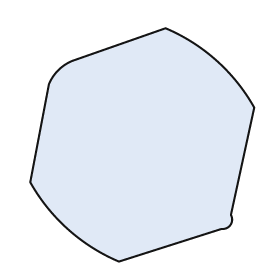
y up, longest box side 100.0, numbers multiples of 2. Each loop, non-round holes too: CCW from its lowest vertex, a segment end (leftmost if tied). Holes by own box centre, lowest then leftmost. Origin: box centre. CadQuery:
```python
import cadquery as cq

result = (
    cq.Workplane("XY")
    .moveTo(-10.0, -50.0)
    .lineTo(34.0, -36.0)
    .threePointArc((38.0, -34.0), (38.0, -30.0))
    .lineTo(48.0, 16.0)
    .threePointArc((32.0, 36.0), (10.0, 50.0))
    .lineTo(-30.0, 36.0)
    .threePointArc((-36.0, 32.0), (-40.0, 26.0))
    .lineTo(-48.0, -16.0)
    .threePointArc((-32.0, -36.0), (-10.0, -50.0))
    .close()
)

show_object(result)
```